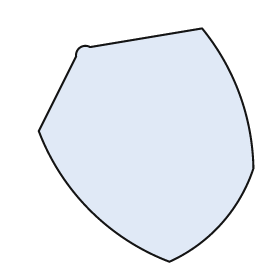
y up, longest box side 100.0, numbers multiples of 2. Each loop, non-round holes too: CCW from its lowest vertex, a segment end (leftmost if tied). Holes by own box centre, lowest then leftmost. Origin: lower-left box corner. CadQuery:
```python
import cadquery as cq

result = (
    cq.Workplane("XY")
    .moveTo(56.0, 0.0)
    .threePointArc((78.0, 16.0), (92.0, 40.0))
    .threePointArc((86.0, 72.0), (70.0, 100.0))
    .lineTo(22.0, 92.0)
    .threePointArc((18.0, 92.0), (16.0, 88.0))
    .lineTo(0.0, 56.0)
    .threePointArc((22.0, 22.0), (56.0, 0.0))
    .close()
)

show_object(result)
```